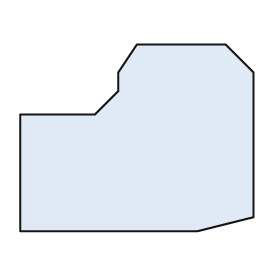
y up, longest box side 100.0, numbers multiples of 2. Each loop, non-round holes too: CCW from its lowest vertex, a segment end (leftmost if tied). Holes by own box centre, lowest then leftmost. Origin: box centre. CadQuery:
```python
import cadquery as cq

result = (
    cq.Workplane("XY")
    .moveTo(-50.0, -40.0)
    .lineTo(26.0, -40.0)
    .lineTo(50.0, -34.0)
    .lineTo(50.0, 28.0)
    .lineTo(38.0, 40.0)
    .lineTo(0.0, 40.0)
    .lineTo(-8.0, 28.0)
    .lineTo(-8.0, 20.0)
    .lineTo(-18.0, 10.0)
    .lineTo(-50.0, 10.0)
    .close()
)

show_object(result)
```